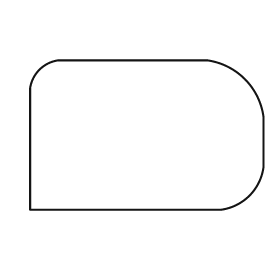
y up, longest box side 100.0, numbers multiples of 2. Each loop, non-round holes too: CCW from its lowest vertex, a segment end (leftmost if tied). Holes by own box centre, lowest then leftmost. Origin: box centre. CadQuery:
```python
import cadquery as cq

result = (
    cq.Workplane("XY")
    .moveTo(-50.0, -32.0)
    .lineTo(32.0, -32.0)
    .threePointArc((44.0, -26.0), (50.0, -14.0))
    .lineTo(50.0, 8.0)
    .threePointArc((42.0, 24.0), (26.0, 32.0))
    .lineTo(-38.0, 32.0)
    .threePointArc((-46.0, 28.0), (-50.0, 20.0))
    .close()
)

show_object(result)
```